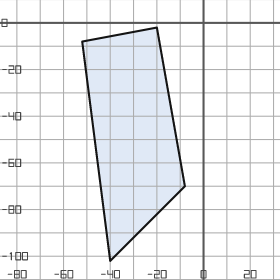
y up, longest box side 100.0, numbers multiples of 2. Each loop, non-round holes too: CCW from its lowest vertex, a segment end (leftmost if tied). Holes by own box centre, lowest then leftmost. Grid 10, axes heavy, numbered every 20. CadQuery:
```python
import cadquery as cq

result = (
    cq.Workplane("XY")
    .moveTo(-40.0, -102.0)
    .lineTo(-8.0, -70.0)
    .lineTo(-20.0, -2.0)
    .lineTo(-52.0, -8.0)
    .close()
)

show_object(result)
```